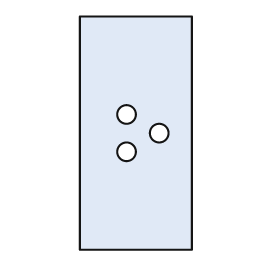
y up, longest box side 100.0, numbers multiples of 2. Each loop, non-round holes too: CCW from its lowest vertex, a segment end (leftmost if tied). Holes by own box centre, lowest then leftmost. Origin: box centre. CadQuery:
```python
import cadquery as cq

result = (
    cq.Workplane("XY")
    .moveTo(-24.0, -50.0)
    .lineTo(24.0, -50.0)
    .lineTo(24.0, 50.0)
    .lineTo(-24.0, 50.0)
    .close()
    .moveTo(-4.0, -8.0)
    .circle(4.0)
    .moveTo(10.0, 0.0)
    .circle(4.0)
    .moveTo(-4.0, 8.0)
    .circle(4.0)
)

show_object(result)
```